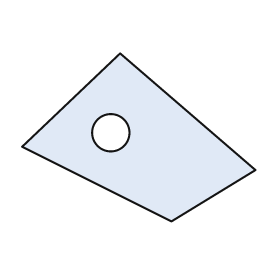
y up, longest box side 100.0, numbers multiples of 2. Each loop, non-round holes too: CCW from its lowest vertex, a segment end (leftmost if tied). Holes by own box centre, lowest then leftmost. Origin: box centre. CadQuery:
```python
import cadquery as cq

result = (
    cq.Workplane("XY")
    .moveTo(14.0, -36.0)
    .lineTo(50.0, -14.0)
    .lineTo(-8.0, 36.0)
    .lineTo(-50.0, -4.0)
    .close()
    .moveTo(-12.0, 2.0)
    .circle(8.0)
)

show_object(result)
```